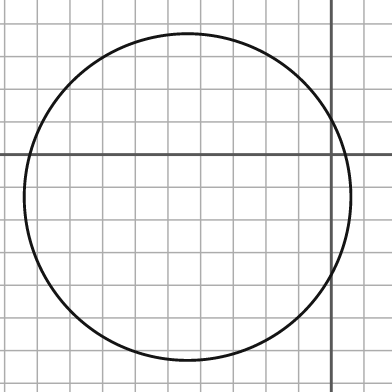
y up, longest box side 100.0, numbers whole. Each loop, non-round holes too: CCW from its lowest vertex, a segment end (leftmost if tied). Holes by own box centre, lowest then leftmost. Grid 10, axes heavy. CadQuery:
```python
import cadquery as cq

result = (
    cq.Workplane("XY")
    .moveTo(-44.0, -13.0)
    .circle(50.0)
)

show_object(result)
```